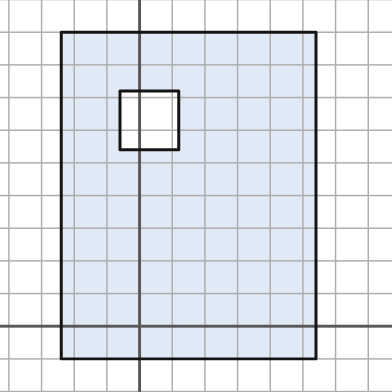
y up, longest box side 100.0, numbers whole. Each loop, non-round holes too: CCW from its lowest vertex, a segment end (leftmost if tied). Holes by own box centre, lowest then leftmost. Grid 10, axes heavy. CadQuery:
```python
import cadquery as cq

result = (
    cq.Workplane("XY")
    .moveTo(-24.0, -10.0)
    .lineTo(54.0, -10.0)
    .lineTo(54.0, 90.0)
    .lineTo(-24.0, 90.0)
    .close()
    .moveTo(-6.0, 54.0)
    .lineTo(12.0, 54.0)
    .lineTo(12.0, 72.0)
    .lineTo(-6.0, 72.0)
    .close()
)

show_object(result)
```